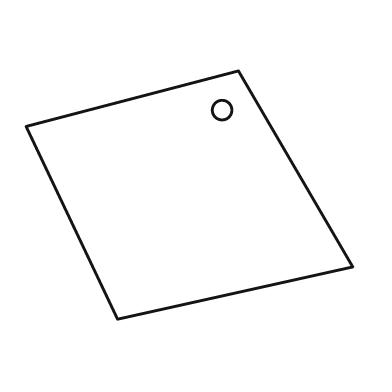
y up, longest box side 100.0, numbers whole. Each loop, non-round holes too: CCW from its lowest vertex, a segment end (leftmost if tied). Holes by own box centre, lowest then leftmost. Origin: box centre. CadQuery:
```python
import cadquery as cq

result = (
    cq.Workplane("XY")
    .moveTo(-22.0, -38.0)
    .lineTo(50.0, -22.0)
    .lineTo(15.0, 38.0)
    .lineTo(-50.0, 21.0)
    .close()
    .moveTo(10.0, 26.0)
    .circle(3.0)
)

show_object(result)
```